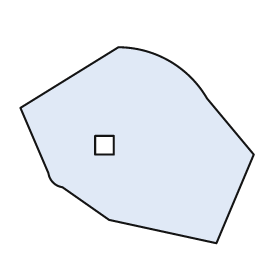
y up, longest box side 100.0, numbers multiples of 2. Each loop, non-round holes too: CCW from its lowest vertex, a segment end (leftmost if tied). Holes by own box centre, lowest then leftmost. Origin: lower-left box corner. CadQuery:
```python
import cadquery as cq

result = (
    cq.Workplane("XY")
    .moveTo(84.0, 0.0)
    .lineTo(100.0, 38.0)
    .lineTo(80.0, 62.0)
    .threePointArc((64.0, 78.0), (42.0, 84.0))
    .lineTo(0.0, 58.0)
    .lineTo(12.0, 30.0)
    .threePointArc((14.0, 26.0), (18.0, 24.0))
    .lineTo(38.0, 10.0)
    .close()
    .moveTo(32.0, 38.0)
    .lineTo(40.0, 38.0)
    .lineTo(40.0, 46.0)
    .lineTo(32.0, 46.0)
    .close()
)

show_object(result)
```